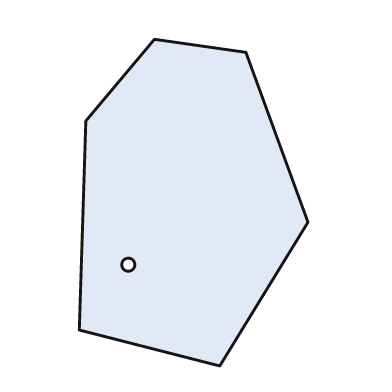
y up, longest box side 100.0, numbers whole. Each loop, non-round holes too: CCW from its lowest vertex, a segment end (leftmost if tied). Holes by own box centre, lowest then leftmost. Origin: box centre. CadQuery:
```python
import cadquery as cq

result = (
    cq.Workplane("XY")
    .moveTo(8.0, -50.0)
    .lineTo(35.0, -6.0)
    .lineTo(16.0, 46.0)
    .lineTo(-12.0, 50.0)
    .lineTo(-33.0, 25.0)
    .lineTo(-35.0, -39.0)
    .close()
    .moveTo(-20.0, -19.0)
    .circle(2.0)
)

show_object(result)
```